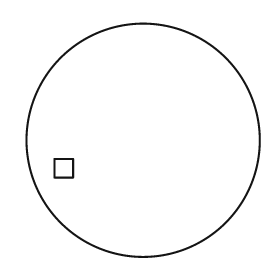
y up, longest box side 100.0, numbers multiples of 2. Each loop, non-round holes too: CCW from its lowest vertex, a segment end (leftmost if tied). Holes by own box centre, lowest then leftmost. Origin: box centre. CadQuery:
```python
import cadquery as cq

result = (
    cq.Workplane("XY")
    .moveTo(0.0, 0.0)
    .circle(50.0)
    .moveTo(-38.0, -16.0)
    .lineTo(-30.0, -16.0)
    .lineTo(-30.0, -8.0)
    .lineTo(-38.0, -8.0)
    .close()
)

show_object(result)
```